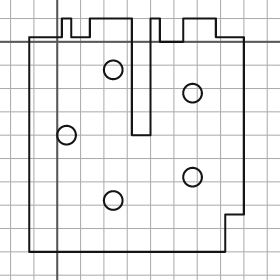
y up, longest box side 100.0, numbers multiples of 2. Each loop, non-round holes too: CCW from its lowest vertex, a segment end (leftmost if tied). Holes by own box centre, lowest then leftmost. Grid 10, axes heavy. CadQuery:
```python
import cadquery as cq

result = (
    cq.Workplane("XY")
    .moveTo(-12.0, -90.0)
    .lineTo(72.0, -90.0)
    .lineTo(72.0, -74.0)
    .lineTo(80.0, -74.0)
    .lineTo(80.0, 2.0)
    .lineTo(68.0, 2.0)
    .lineTo(68.0, 10.0)
    .lineTo(54.0, 10.0)
    .lineTo(54.0, 0.0)
    .lineTo(44.0, 0.0)
    .lineTo(44.0, 10.0)
    .lineTo(40.0, 10.0)
    .lineTo(40.0, -40.0)
    .lineTo(32.0, -40.0)
    .lineTo(32.0, 10.0)
    .lineTo(14.0, 10.0)
    .lineTo(14.0, 2.0)
    .lineTo(6.0, 2.0)
    .lineTo(6.0, 10.0)
    .lineTo(2.0, 10.0)
    .lineTo(2.0, 2.0)
    .lineTo(-12.0, 2.0)
    .close()
    .moveTo(24.0, -68.0)
    .circle(4.0)
    .moveTo(58.0, -58.0)
    .circle(4.0)
    .moveTo(4.0, -40.0)
    .circle(4.0)
    .moveTo(58.0, -22.0)
    .circle(4.0)
    .moveTo(24.0, -12.0)
    .circle(4.0)
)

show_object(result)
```